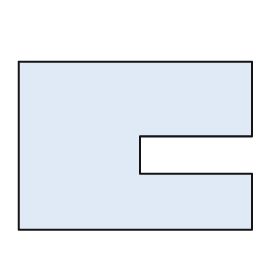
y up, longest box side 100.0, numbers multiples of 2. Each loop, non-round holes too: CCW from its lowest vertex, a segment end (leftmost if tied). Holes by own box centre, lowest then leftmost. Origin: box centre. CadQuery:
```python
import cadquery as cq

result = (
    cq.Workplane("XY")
    .moveTo(-50.0, -36.0)
    .lineTo(50.0, -36.0)
    .lineTo(50.0, -12.0)
    .lineTo(2.0, -12.0)
    .lineTo(2.0, 4.0)
    .lineTo(50.0, 4.0)
    .lineTo(50.0, 36.0)
    .lineTo(-50.0, 36.0)
    .close()
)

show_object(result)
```